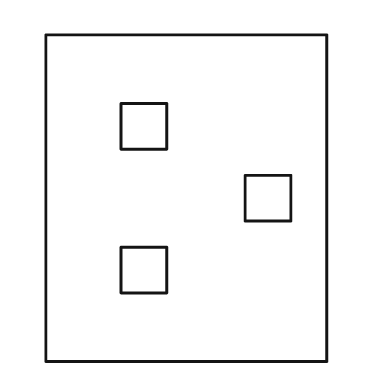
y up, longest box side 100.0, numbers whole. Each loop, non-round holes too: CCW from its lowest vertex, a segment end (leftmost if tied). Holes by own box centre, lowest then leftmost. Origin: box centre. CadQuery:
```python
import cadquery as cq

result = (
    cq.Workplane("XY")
    .moveTo(-43.0, -50.0)
    .lineTo(43.0, -50.0)
    .lineTo(43.0, 50.0)
    .lineTo(-43.0, 50.0)
    .close()
    .moveTo(-20.0, -29.0)
    .lineTo(-6.0, -29.0)
    .lineTo(-6.0, -15.0)
    .lineTo(-20.0, -15.0)
    .close()
    .moveTo(18.0, -7.0)
    .lineTo(32.0, -7.0)
    .lineTo(32.0, 7.0)
    .lineTo(18.0, 7.0)
    .close()
    .moveTo(-20.0, 15.0)
    .lineTo(-6.0, 15.0)
    .lineTo(-6.0, 29.0)
    .lineTo(-20.0, 29.0)
    .close()
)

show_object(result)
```